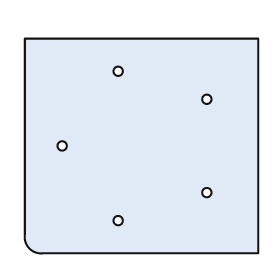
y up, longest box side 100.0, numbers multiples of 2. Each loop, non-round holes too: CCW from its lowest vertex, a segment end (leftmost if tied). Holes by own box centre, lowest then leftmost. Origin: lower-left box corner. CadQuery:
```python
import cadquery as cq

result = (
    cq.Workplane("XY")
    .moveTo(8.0, 0.0)
    .lineTo(100.0, 0.0)
    .lineTo(100.0, 92.0)
    .lineTo(0.0, 92.0)
    .lineTo(0.0, 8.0)
    .threePointArc((2.0, 2.0), (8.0, 0.0))
    .close()
    .moveTo(40.0, 14.0)
    .circle(2.0)
    .moveTo(78.0, 26.0)
    .circle(2.0)
    .moveTo(16.0, 46.0)
    .circle(2.0)
    .moveTo(78.0, 66.0)
    .circle(2.0)
    .moveTo(40.0, 78.0)
    .circle(2.0)
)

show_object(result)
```